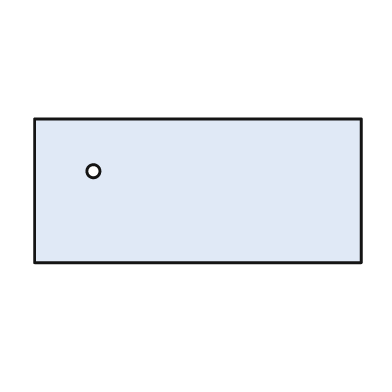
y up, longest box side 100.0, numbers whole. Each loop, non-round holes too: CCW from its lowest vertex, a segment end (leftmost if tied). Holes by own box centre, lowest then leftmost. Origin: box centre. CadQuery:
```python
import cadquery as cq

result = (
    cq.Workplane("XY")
    .moveTo(-50.0, -22.0)
    .lineTo(50.0, -22.0)
    .lineTo(50.0, 22.0)
    .lineTo(-50.0, 22.0)
    .close()
    .moveTo(-32.0, 6.0)
    .circle(2.0)
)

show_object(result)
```